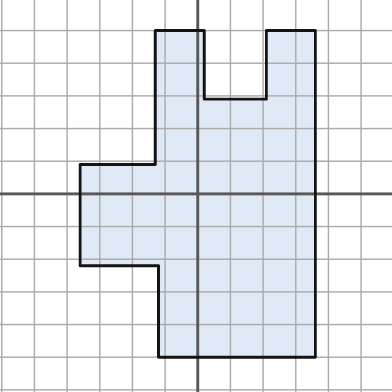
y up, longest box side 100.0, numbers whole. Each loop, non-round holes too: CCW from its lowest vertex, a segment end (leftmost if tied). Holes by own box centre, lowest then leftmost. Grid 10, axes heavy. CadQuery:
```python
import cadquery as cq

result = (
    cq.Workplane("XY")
    .moveTo(-12.0, -50.0)
    .lineTo(36.0, -50.0)
    .lineTo(36.0, 50.0)
    .lineTo(21.0, 50.0)
    .lineTo(21.0, 29.0)
    .lineTo(2.0, 29.0)
    .lineTo(2.0, 50.0)
    .lineTo(-13.0, 50.0)
    .lineTo(-13.0, 9.0)
    .lineTo(-36.0, 9.0)
    .lineTo(-36.0, -22.0)
    .lineTo(-12.0, -22.0)
    .close()
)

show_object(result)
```